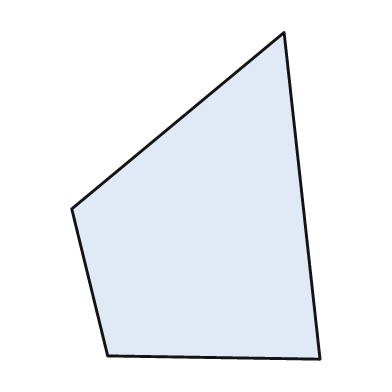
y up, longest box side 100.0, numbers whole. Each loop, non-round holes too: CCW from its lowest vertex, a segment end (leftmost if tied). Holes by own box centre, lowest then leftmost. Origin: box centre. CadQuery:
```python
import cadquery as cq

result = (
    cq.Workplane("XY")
    .moveTo(38.0, -50.0)
    .lineTo(27.0, 50.0)
    .lineTo(-38.0, -4.0)
    .lineTo(-27.0, -49.0)
    .close()
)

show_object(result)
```